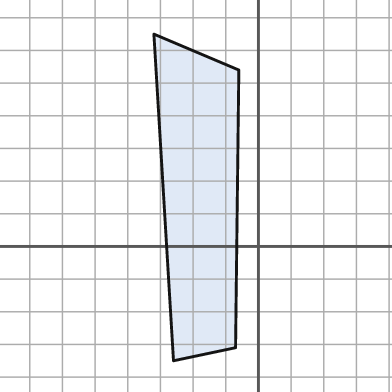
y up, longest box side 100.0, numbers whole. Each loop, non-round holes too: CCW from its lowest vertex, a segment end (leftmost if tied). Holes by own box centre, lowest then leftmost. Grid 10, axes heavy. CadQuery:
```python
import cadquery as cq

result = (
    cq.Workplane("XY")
    .moveTo(-26.0, -35.0)
    .lineTo(-7.0, -31.0)
    .lineTo(-6.0, 54.0)
    .lineTo(-32.0, 65.0)
    .close()
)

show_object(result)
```